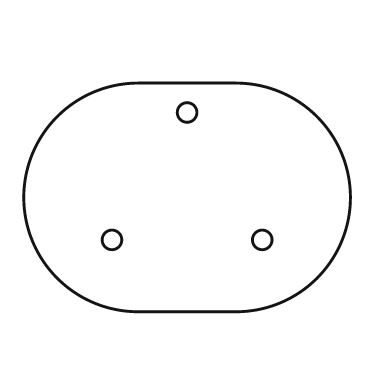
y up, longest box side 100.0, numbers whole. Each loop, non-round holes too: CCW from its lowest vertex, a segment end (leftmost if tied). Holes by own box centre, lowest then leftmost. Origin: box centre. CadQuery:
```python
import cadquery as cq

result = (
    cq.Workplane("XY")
    .moveTo(-15.0, -35.0)
    .lineTo(15.0, -35.0)
    .threePointArc((50.0, 0.0), (15.0, 35.0))
    .lineTo(-15.0, 35.0)
    .threePointArc((-50.0, 0.0), (-15.0, -35.0))
    .close()
    .moveTo(-23.0, -13.0)
    .circle(3.0)
    .moveTo(23.0, -13.0)
    .circle(3.0)
    .moveTo(0.0, 26.0)
    .circle(3.0)
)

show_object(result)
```